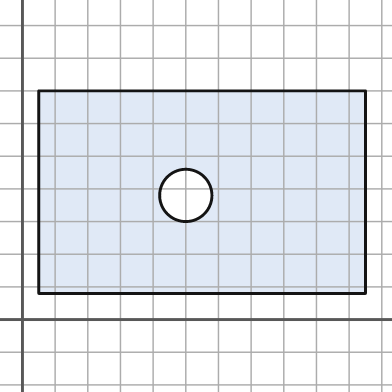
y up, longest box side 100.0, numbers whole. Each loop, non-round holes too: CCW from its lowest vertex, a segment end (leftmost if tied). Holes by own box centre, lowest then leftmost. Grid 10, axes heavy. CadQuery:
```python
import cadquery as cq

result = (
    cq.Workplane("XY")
    .moveTo(5.0, 8.0)
    .lineTo(105.0, 8.0)
    .lineTo(105.0, 70.0)
    .lineTo(5.0, 70.0)
    .close()
    .moveTo(50.0, 38.0)
    .circle(8.0)
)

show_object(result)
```